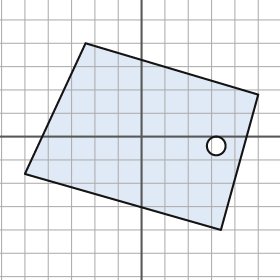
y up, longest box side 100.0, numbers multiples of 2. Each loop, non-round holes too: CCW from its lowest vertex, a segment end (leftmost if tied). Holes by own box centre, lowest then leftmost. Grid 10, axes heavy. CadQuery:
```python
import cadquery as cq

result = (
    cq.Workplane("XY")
    .moveTo(34.0, -40.0)
    .lineTo(50.0, 18.0)
    .lineTo(-24.0, 40.0)
    .lineTo(-50.0, -16.0)
    .close()
    .moveTo(32.0, -4.0)
    .circle(4.0)
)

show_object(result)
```